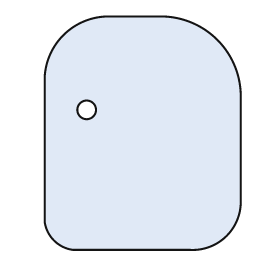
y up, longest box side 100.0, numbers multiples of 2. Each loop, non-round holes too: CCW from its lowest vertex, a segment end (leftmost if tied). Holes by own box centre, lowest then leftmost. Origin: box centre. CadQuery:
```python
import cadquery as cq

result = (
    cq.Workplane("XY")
    .moveTo(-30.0, -50.0)
    .lineTo(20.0, -50.0)
    .threePointArc((36.0, -44.0), (42.0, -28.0))
    .lineTo(42.0, 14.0)
    .threePointArc((32.0, 40.0), (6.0, 50.0))
    .lineTo(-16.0, 50.0)
    .threePointArc((-34.0, 42.0), (-42.0, 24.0))
    .lineTo(-42.0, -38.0)
    .threePointArc((-38.0, -46.0), (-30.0, -50.0))
    .close()
    .moveTo(-24.0, 10.0)
    .circle(4.0)
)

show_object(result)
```